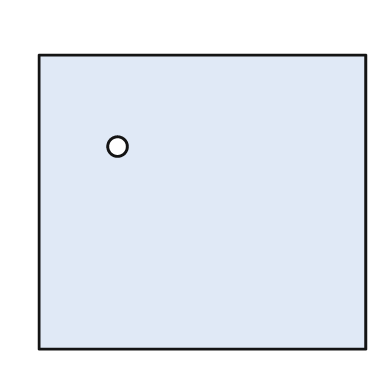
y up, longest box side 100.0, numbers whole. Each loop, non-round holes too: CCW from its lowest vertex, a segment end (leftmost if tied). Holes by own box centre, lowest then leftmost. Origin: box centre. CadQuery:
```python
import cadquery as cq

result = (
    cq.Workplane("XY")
    .moveTo(-50.0, -45.0)
    .lineTo(50.0, -45.0)
    .lineTo(50.0, 45.0)
    .lineTo(-50.0, 45.0)
    .close()
    .moveTo(-26.0, 17.0)
    .circle(3.0)
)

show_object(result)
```